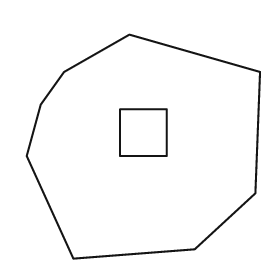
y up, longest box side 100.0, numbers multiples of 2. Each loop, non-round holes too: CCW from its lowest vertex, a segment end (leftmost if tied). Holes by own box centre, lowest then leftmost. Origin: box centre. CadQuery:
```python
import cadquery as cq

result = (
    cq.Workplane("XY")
    .moveTo(-30.0, -48.0)
    .lineTo(22.0, -44.0)
    .lineTo(48.0, -20.0)
    .lineTo(50.0, 32.0)
    .lineTo(-6.0, 48.0)
    .lineTo(-34.0, 32.0)
    .lineTo(-44.0, 18.0)
    .lineTo(-50.0, -4.0)
    .close()
    .moveTo(-10.0, -4.0)
    .lineTo(10.0, -4.0)
    .lineTo(10.0, 16.0)
    .lineTo(-10.0, 16.0)
    .close()
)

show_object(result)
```